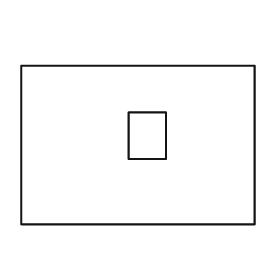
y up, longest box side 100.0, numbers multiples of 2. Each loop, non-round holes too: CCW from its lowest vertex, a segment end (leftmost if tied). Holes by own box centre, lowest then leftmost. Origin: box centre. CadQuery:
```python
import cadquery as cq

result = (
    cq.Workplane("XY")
    .moveTo(-50.0, -34.0)
    .lineTo(50.0, -34.0)
    .lineTo(50.0, 34.0)
    .lineTo(-50.0, 34.0)
    .close()
    .moveTo(-4.0, -6.0)
    .lineTo(12.0, -6.0)
    .lineTo(12.0, 14.0)
    .lineTo(-4.0, 14.0)
    .close()
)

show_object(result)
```